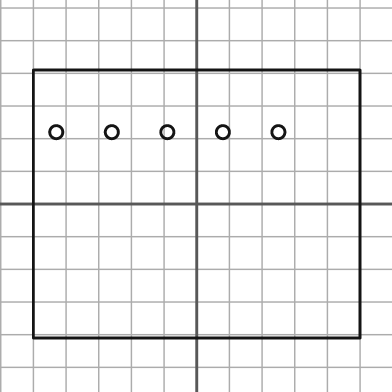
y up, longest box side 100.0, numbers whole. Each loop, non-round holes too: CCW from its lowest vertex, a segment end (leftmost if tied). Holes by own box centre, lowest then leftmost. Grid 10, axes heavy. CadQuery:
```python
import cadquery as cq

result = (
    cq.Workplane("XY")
    .moveTo(-50.0, -41.0)
    .lineTo(50.0, -41.0)
    .lineTo(50.0, 41.0)
    .lineTo(-50.0, 41.0)
    .close()
    .moveTo(-43.0, 22.0)
    .circle(2.0)
    .moveTo(-26.0, 22.0)
    .circle(2.0)
    .moveTo(-9.0, 22.0)
    .circle(2.0)
    .moveTo(8.0, 22.0)
    .circle(2.0)
    .moveTo(25.0, 22.0)
    .circle(2.0)
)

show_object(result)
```